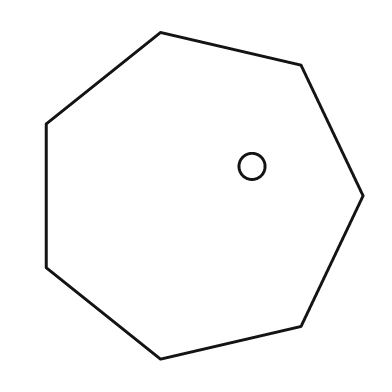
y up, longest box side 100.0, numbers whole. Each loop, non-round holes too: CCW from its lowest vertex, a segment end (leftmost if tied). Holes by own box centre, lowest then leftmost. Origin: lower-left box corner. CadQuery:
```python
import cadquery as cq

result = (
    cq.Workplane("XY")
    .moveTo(35.0, 0.0)
    .lineTo(78.0, 10.0)
    .lineTo(97.0, 50.0)
    .lineTo(78.0, 90.0)
    .lineTo(35.0, 100.0)
    .lineTo(0.0, 72.0)
    .lineTo(0.0, 28.0)
    .close()
    .moveTo(63.0, 59.0)
    .circle(4.0)
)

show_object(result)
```